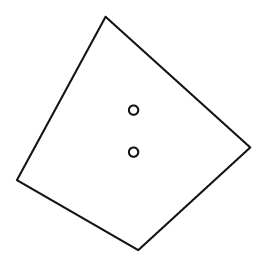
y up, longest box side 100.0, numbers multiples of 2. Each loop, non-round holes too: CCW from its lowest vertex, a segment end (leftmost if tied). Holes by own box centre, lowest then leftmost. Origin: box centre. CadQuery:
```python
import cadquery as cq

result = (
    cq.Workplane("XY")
    .moveTo(2.0, -50.0)
    .lineTo(50.0, -6.0)
    .lineTo(-12.0, 50.0)
    .lineTo(-50.0, -20.0)
    .close()
    .moveTo(0.0, -8.0)
    .circle(2.0)
    .moveTo(0.0, 10.0)
    .circle(2.0)
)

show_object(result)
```